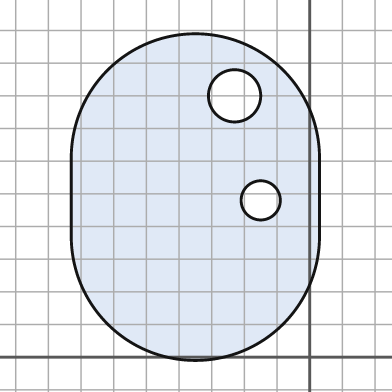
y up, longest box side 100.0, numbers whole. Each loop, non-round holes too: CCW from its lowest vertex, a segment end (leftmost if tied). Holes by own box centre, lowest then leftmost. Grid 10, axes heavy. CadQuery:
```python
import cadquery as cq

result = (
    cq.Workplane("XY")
    .moveTo(-73.0, 37.0)
    .threePointArc((-35.0, -1.0), (3.0, 37.0))
    .lineTo(3.0, 61.0)
    .threePointArc((-35.0, 99.0), (-73.0, 61.0))
    .close()
    .moveTo(-15.0, 48.0)
    .circle(6.0)
    .moveTo(-23.0, 80.0)
    .circle(8.0)
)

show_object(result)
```